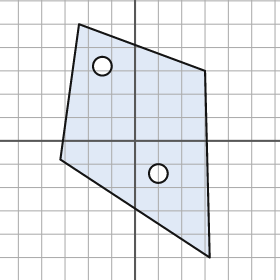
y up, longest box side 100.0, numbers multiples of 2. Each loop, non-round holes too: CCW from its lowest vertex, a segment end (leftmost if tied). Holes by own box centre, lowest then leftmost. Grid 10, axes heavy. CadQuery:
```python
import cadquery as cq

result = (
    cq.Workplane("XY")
    .moveTo(32.0, -50.0)
    .lineTo(30.0, 30.0)
    .lineTo(-24.0, 50.0)
    .lineTo(-32.0, -8.0)
    .close()
    .moveTo(10.0, -14.0)
    .circle(4.0)
    .moveTo(-14.0, 32.0)
    .circle(4.0)
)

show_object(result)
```